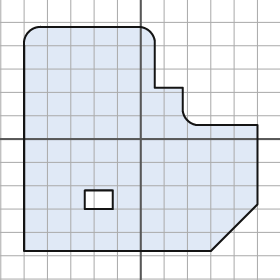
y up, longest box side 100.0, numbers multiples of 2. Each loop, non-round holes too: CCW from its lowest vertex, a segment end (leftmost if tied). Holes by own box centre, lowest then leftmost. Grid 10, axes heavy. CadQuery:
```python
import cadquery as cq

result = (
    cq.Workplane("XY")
    .moveTo(-50.0, -48.0)
    .lineTo(30.0, -48.0)
    .lineTo(50.0, -28.0)
    .lineTo(50.0, 6.0)
    .lineTo(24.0, 6.0)
    .threePointArc((20.0, 8.0), (18.0, 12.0))
    .lineTo(18.0, 22.0)
    .lineTo(6.0, 22.0)
    .lineTo(6.0, 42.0)
    .threePointArc((4.0, 46.0), (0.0, 48.0))
    .lineTo(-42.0, 48.0)
    .threePointArc((-48.0, 46.0), (-50.0, 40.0))
    .close()
    .moveTo(-24.0, -30.0)
    .lineTo(-12.0, -30.0)
    .lineTo(-12.0, -22.0)
    .lineTo(-24.0, -22.0)
    .close()
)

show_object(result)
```